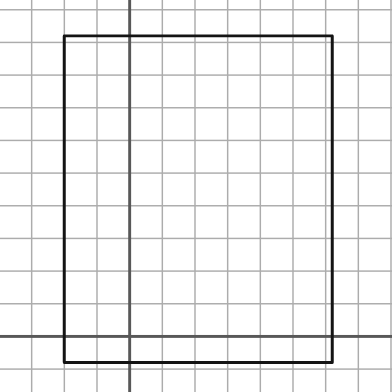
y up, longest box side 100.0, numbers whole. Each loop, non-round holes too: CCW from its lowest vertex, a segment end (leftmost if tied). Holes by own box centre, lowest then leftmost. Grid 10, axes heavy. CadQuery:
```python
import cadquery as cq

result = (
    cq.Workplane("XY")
    .moveTo(-20.0, -8.0)
    .lineTo(62.0, -8.0)
    .lineTo(62.0, 92.0)
    .lineTo(-20.0, 92.0)
    .close()
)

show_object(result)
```